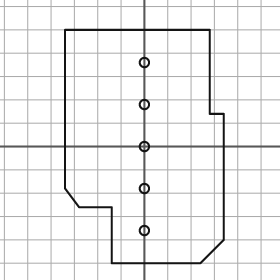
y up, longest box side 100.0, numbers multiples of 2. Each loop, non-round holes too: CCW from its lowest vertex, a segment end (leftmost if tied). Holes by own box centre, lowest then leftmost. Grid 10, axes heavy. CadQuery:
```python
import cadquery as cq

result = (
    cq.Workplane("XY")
    .moveTo(-14.0, -50.0)
    .lineTo(24.0, -50.0)
    .lineTo(34.0, -40.0)
    .lineTo(34.0, 14.0)
    .lineTo(28.0, 14.0)
    .lineTo(28.0, 50.0)
    .lineTo(-34.0, 50.0)
    .lineTo(-34.0, -18.0)
    .lineTo(-28.0, -26.0)
    .lineTo(-14.0, -26.0)
    .close()
    .moveTo(0.0, -36.0)
    .circle(2.0)
    .moveTo(0.0, -18.0)
    .circle(2.0)
    .moveTo(0.0, 0.0)
    .circle(2.0)
    .moveTo(0.0, 18.0)
    .circle(2.0)
    .moveTo(0.0, 36.0)
    .circle(2.0)
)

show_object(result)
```